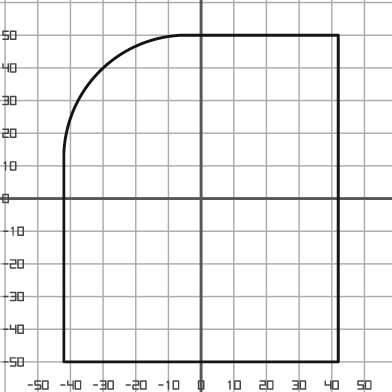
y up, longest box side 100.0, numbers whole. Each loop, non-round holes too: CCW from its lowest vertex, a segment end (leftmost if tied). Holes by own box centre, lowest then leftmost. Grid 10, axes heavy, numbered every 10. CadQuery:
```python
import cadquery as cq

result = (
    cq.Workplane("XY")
    .moveTo(-42.0, -50.0)
    .lineTo(42.0, -50.0)
    .lineTo(42.0, 50.0)
    .lineTo(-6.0, 50.0)
    .threePointArc((-31.0, 39.0), (-42.0, 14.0))
    .close()
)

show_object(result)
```